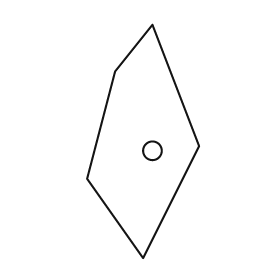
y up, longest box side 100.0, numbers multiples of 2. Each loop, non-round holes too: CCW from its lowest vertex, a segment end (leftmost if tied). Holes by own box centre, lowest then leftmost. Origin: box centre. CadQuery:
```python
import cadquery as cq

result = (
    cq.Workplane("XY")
    .moveTo(0.0, -50.0)
    .lineTo(24.0, -2.0)
    .lineTo(4.0, 50.0)
    .lineTo(-12.0, 30.0)
    .lineTo(-24.0, -16.0)
    .close()
    .moveTo(4.0, -4.0)
    .circle(4.0)
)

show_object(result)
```